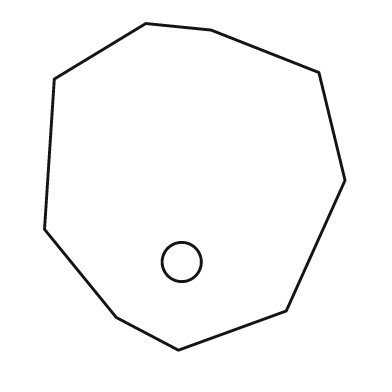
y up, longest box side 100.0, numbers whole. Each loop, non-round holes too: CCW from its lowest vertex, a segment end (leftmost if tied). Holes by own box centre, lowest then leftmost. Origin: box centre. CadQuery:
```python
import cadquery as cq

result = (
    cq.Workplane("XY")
    .moveTo(-5.0, -50.0)
    .lineTo(28.0, -38.0)
    .lineTo(46.0, 2.0)
    .lineTo(38.0, 35.0)
    .lineTo(5.0, 48.0)
    .lineTo(-15.0, 50.0)
    .lineTo(-43.0, 33.0)
    .lineTo(-46.0, -13.0)
    .lineTo(-24.0, -40.0)
    .close()
    .moveTo(-4.0, -23.0)
    .circle(6.0)
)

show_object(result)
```